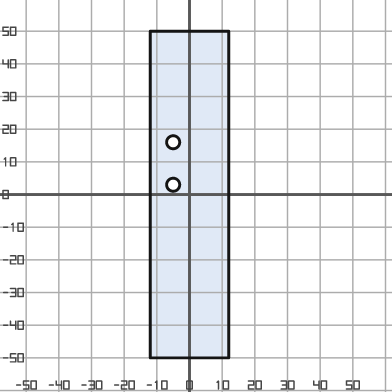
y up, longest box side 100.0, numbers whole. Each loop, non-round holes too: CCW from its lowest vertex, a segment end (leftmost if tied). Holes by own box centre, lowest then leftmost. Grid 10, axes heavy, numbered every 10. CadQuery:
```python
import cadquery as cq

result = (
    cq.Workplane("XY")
    .moveTo(-12.0, -50.0)
    .lineTo(12.0, -50.0)
    .lineTo(12.0, 50.0)
    .lineTo(-12.0, 50.0)
    .close()
    .moveTo(-5.0, 3.0)
    .circle(2.0)
    .moveTo(-5.0, 16.0)
    .circle(2.0)
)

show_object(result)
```